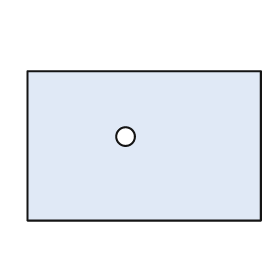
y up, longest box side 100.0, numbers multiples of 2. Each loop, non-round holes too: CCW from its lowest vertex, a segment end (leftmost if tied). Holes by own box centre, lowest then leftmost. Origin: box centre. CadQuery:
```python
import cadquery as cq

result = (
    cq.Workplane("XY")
    .moveTo(-50.0, -32.0)
    .lineTo(50.0, -32.0)
    .lineTo(50.0, 32.0)
    .lineTo(-50.0, 32.0)
    .close()
    .moveTo(-8.0, 4.0)
    .circle(4.0)
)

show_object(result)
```